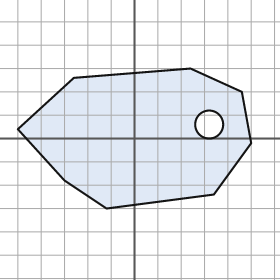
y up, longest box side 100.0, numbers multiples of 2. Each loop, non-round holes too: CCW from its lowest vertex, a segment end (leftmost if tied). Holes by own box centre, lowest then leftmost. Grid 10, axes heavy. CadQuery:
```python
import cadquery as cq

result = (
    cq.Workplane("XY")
    .moveTo(-12.0, -30.0)
    .lineTo(34.0, -24.0)
    .lineTo(50.0, -2.0)
    .lineTo(46.0, 20.0)
    .lineTo(24.0, 30.0)
    .lineTo(-26.0, 26.0)
    .lineTo(-50.0, 4.0)
    .lineTo(-30.0, -18.0)
    .close()
    .moveTo(32.0, 6.0)
    .circle(6.0)
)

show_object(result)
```